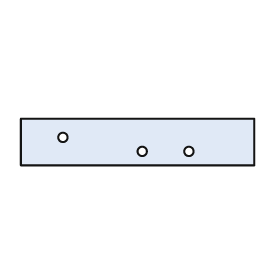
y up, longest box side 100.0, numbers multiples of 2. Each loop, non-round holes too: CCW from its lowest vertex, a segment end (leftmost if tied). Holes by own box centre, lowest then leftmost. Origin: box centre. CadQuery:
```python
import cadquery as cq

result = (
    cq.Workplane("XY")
    .moveTo(-50.0, -10.0)
    .lineTo(50.0, -10.0)
    .lineTo(50.0, 10.0)
    .lineTo(-50.0, 10.0)
    .close()
    .moveTo(2.0, -4.0)
    .circle(2.0)
    .moveTo(22.0, -4.0)
    .circle(2.0)
    .moveTo(-32.0, 2.0)
    .circle(2.0)
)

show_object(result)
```